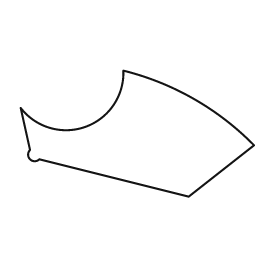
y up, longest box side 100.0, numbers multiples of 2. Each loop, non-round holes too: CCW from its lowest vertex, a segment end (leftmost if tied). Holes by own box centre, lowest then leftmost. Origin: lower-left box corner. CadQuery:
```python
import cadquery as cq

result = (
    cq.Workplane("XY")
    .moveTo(72.0, 0.0)
    .lineTo(100.0, 22.0)
    .threePointArc((74.0, 42.0), (44.0, 54.0))
    .threePointArc((28.0, 30.0), (0.0, 38.0))
    .lineTo(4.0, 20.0)
    .threePointArc((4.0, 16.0), (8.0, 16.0))
    .close()
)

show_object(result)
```